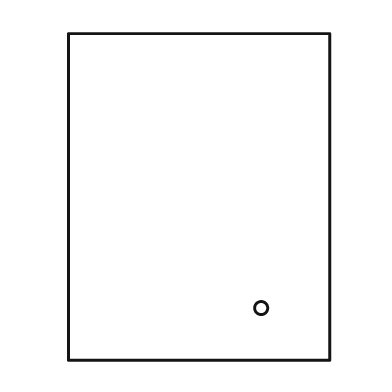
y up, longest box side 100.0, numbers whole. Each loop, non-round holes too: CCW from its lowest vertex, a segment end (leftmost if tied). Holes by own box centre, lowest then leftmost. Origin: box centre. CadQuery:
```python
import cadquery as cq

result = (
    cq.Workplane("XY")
    .moveTo(-40.0, -50.0)
    .lineTo(40.0, -50.0)
    .lineTo(40.0, 50.0)
    .lineTo(-40.0, 50.0)
    .close()
    .moveTo(19.0, -34.0)
    .circle(2.0)
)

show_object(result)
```